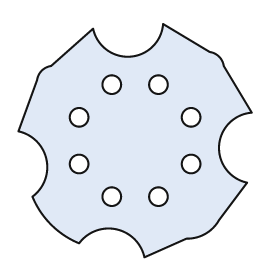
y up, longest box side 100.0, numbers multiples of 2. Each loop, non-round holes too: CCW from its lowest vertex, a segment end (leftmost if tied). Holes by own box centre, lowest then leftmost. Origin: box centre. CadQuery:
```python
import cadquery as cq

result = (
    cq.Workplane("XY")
    .moveTo(4.0, -50.0)
    .lineTo(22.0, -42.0)
    .threePointArc((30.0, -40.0), (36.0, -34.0))
    .lineTo(48.0, -18.0)
    .threePointArc((36.0, -2.0), (50.0, 12.0))
    .lineTo(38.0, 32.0)
    .threePointArc((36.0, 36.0), (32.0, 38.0))
    .lineTo(12.0, 50.0)
    .threePointArc((-2.0, 36.0), (-18.0, 48.0))
    .lineTo(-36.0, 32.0)
    .threePointArc((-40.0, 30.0), (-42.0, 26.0))
    .lineTo(-50.0, 4.0)
    .threePointArc((-38.0, -8.0), (-44.0, -24.0))
    .threePointArc((-36.0, -36.0), (-24.0, -44.0))
    .threePointArc((-8.0, -38.0), (4.0, -50.0))
    .close()
    .moveTo(-10.0, -24.0)
    .circle(4.0)
    .moveTo(10.0, -24.0)
    .circle(4.0)
    .moveTo(-24.0, -10.0)
    .circle(4.0)
    .moveTo(24.0, -10.0)
    .circle(4.0)
    .moveTo(-24.0, 10.0)
    .circle(4.0)
    .moveTo(24.0, 10.0)
    .circle(4.0)
    .moveTo(-10.0, 24.0)
    .circle(4.0)
    .moveTo(10.0, 24.0)
    .circle(4.0)
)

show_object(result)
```